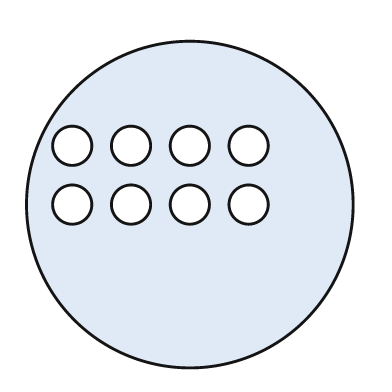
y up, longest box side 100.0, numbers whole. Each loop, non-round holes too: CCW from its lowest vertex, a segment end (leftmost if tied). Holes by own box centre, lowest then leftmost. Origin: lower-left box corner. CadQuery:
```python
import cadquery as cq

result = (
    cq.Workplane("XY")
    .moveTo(50.0, 50.0)
    .circle(50.0)
    .moveTo(14.0, 50.0)
    .circle(6.0)
    .moveTo(32.0, 50.0)
    .circle(6.0)
    .moveTo(50.0, 50.0)
    .circle(6.0)
    .moveTo(68.0, 50.0)
    .circle(6.0)
    .moveTo(14.0, 68.0)
    .circle(6.0)
    .moveTo(32.0, 68.0)
    .circle(6.0)
    .moveTo(50.0, 68.0)
    .circle(6.0)
    .moveTo(68.0, 68.0)
    .circle(6.0)
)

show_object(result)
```